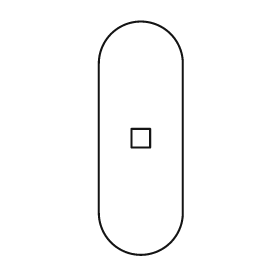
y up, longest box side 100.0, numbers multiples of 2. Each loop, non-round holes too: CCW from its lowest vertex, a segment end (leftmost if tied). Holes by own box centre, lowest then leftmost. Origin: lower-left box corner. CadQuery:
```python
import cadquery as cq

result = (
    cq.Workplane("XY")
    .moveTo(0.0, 18.0)
    .threePointArc((18.0, 0.0), (36.0, 18.0))
    .lineTo(36.0, 82.0)
    .threePointArc((18.0, 100.0), (0.0, 82.0))
    .close()
    .moveTo(14.0, 46.0)
    .lineTo(22.0, 46.0)
    .lineTo(22.0, 54.0)
    .lineTo(14.0, 54.0)
    .close()
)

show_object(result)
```